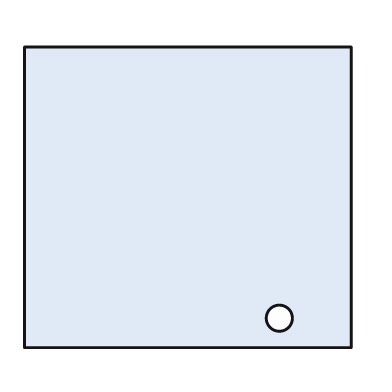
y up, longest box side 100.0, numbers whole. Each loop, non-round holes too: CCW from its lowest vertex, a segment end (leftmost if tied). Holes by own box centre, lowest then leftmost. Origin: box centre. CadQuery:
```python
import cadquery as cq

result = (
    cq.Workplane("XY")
    .moveTo(-50.0, -46.0)
    .lineTo(50.0, -46.0)
    .lineTo(50.0, 46.0)
    .lineTo(-50.0, 46.0)
    .close()
    .moveTo(28.0, -37.0)
    .circle(4.0)
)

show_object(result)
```